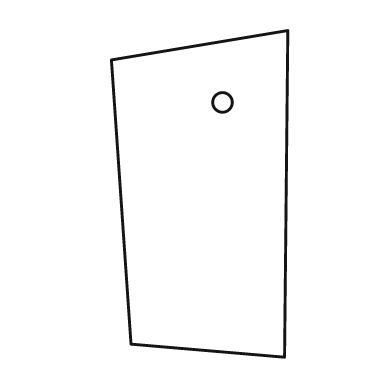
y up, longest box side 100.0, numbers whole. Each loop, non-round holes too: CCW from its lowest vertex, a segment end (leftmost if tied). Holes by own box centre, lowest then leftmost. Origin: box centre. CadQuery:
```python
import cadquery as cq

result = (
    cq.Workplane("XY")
    .moveTo(26.0, -50.0)
    .lineTo(27.0, 50.0)
    .lineTo(-27.0, 41.0)
    .lineTo(-21.0, -46.0)
    .close()
    .moveTo(7.0, 28.0)
    .circle(3.0)
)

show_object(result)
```